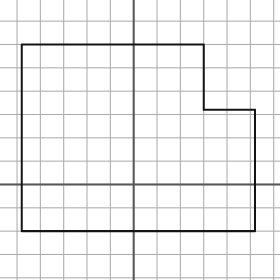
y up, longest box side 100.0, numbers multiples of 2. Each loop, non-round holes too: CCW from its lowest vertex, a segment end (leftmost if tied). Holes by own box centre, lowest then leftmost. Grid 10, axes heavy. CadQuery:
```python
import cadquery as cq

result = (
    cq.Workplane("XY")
    .moveTo(-48.0, -20.0)
    .lineTo(52.0, -20.0)
    .lineTo(52.0, 32.0)
    .lineTo(30.0, 32.0)
    .lineTo(30.0, 60.0)
    .lineTo(-48.0, 60.0)
    .close()
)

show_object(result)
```